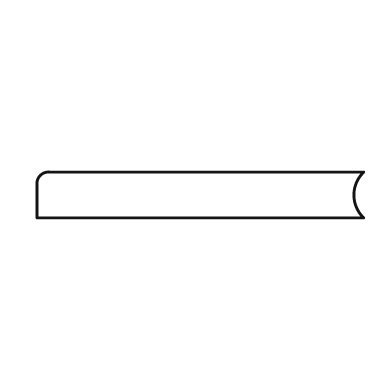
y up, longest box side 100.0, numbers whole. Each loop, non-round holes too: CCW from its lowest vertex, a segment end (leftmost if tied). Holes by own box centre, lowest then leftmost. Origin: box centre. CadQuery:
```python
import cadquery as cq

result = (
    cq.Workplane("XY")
    .moveTo(-50.0, -7.0)
    .lineTo(50.0, -7.0)
    .threePointArc((47.0, 0.0), (50.0, 7.0))
    .lineTo(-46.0, 7.0)
    .threePointArc((-49.0, 6.0), (-50.0, 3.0))
    .close()
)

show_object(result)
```